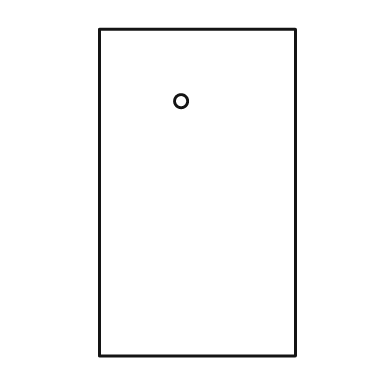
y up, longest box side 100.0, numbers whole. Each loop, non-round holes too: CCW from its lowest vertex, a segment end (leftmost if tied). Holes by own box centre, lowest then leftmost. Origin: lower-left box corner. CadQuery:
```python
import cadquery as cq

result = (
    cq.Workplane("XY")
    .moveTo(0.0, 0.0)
    .lineTo(60.0, 0.0)
    .lineTo(60.0, 100.0)
    .lineTo(0.0, 100.0)
    .close()
    .moveTo(25.0, 78.0)
    .circle(2.0)
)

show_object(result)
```